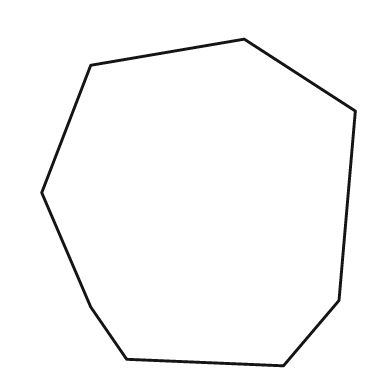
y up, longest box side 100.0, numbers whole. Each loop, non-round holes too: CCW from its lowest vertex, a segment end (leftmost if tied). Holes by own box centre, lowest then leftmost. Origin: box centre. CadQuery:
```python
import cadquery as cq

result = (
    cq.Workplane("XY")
    .moveTo(26.0, -50.0)
    .lineTo(43.0, -30.0)
    .lineTo(48.0, 28.0)
    .lineTo(14.0, 50.0)
    .lineTo(-33.0, 42.0)
    .lineTo(-48.0, 3.0)
    .lineTo(-33.0, -32.0)
    .lineTo(-22.0, -48.0)
    .close()
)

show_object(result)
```